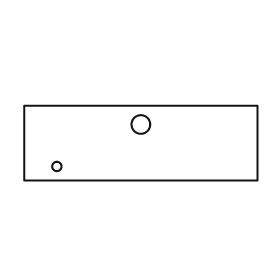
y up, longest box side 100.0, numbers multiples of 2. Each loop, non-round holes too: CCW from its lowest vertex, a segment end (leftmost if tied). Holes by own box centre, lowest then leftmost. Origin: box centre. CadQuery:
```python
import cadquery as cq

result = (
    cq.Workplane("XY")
    .moveTo(-50.0, -16.0)
    .lineTo(50.0, -16.0)
    .lineTo(50.0, 16.0)
    .lineTo(-50.0, 16.0)
    .close()
    .moveTo(-36.0, -10.0)
    .circle(2.0)
    .moveTo(0.0, 8.0)
    .circle(4.0)
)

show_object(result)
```